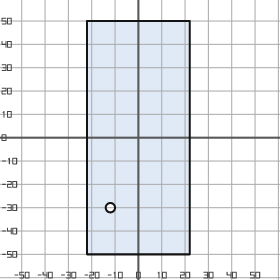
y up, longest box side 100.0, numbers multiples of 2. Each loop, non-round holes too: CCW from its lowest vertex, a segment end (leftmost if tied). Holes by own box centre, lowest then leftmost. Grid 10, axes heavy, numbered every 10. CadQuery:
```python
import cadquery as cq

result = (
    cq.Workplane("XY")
    .moveTo(-22.0, -50.0)
    .lineTo(22.0, -50.0)
    .lineTo(22.0, 50.0)
    .lineTo(-22.0, 50.0)
    .close()
    .moveTo(-12.0, -30.0)
    .circle(2.0)
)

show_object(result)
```